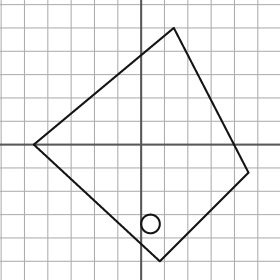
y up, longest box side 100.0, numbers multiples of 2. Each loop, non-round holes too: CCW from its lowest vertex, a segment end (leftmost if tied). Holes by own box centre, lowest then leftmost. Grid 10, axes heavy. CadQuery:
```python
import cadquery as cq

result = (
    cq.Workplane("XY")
    .moveTo(8.0, -50.0)
    .lineTo(46.0, -12.0)
    .lineTo(14.0, 50.0)
    .lineTo(-46.0, 0.0)
    .close()
    .moveTo(4.0, -34.0)
    .circle(4.0)
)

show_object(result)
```